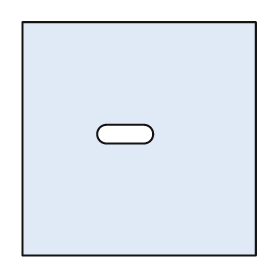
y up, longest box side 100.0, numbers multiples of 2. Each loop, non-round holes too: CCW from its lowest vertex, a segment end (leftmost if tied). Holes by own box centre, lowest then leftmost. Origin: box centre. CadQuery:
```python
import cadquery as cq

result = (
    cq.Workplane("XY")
    .moveTo(-50.0, -50.0)
    .lineTo(50.0, -50.0)
    .lineTo(50.0, 50.0)
    .lineTo(-50.0, 50.0)
    .close()
    .moveTo(-14.0, -2.0)
    .lineTo(2.0, -2.0)
    .threePointArc((6.0, 2.0), (2.0, 6.0))
    .lineTo(-14.0, 6.0)
    .threePointArc((-18.0, 2.0), (-14.0, -2.0))
    .close()
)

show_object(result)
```